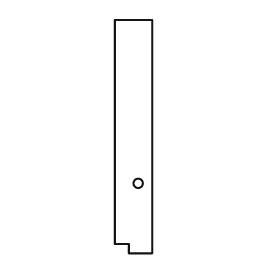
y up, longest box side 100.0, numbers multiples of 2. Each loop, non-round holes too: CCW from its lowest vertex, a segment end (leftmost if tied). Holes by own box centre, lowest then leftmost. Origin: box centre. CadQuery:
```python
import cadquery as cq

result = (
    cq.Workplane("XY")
    .moveTo(-2.0, -50.0)
    .lineTo(8.0, -50.0)
    .lineTo(8.0, 50.0)
    .lineTo(-8.0, 50.0)
    .lineTo(-8.0, -46.0)
    .lineTo(-2.0, -46.0)
    .close()
    .moveTo(2.0, -20.0)
    .circle(2.0)
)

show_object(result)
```